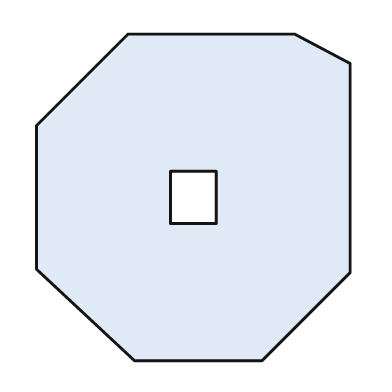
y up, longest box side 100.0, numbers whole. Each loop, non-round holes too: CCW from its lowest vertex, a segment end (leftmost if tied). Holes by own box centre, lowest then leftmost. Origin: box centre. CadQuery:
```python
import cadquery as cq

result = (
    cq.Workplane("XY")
    .moveTo(-18.0, -50.0)
    .lineTo(21.0, -50.0)
    .lineTo(48.0, -23.0)
    .lineTo(48.0, 41.0)
    .lineTo(31.0, 50.0)
    .lineTo(-20.0, 50.0)
    .lineTo(-48.0, 22.0)
    .lineTo(-48.0, -22.0)
    .close()
    .moveTo(-7.0, -8.0)
    .lineTo(7.0, -8.0)
    .lineTo(7.0, 8.0)
    .lineTo(-7.0, 8.0)
    .close()
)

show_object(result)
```